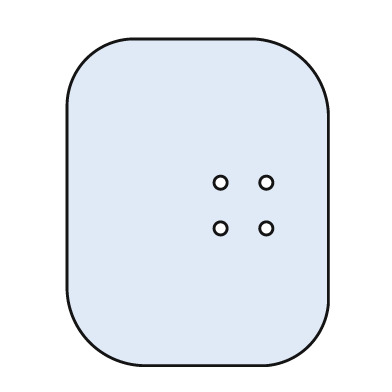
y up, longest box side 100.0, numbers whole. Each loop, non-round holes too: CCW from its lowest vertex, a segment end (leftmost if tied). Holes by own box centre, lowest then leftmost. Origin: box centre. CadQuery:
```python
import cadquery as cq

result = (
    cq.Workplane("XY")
    .moveTo(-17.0, -50.0)
    .lineTo(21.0, -50.0)
    .threePointArc((34.0, -44.0), (40.0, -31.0))
    .lineTo(40.0, 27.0)
    .threePointArc((33.0, 43.0), (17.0, 50.0))
    .lineTo(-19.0, 50.0)
    .threePointArc((-34.0, 44.0), (-40.0, 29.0))
    .lineTo(-40.0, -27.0)
    .threePointArc((-33.0, -43.0), (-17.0, -50.0))
    .close()
    .moveTo(7.0, -8.0)
    .circle(2.0)
    .moveTo(21.0, -8.0)
    .circle(2.0)
    .moveTo(7.0, 6.0)
    .circle(2.0)
    .moveTo(21.0, 6.0)
    .circle(2.0)
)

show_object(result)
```